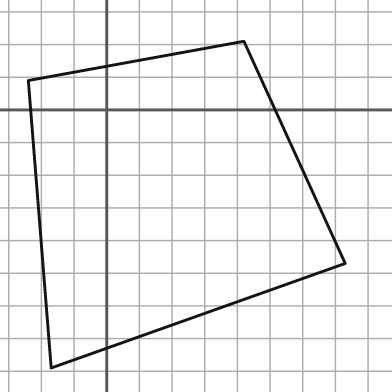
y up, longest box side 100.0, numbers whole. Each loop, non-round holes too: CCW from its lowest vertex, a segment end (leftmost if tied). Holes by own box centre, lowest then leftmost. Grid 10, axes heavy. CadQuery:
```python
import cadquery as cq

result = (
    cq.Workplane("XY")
    .moveTo(-17.0, -79.0)
    .lineTo(73.0, -47.0)
    .lineTo(42.0, 21.0)
    .lineTo(-24.0, 9.0)
    .close()
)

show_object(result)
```